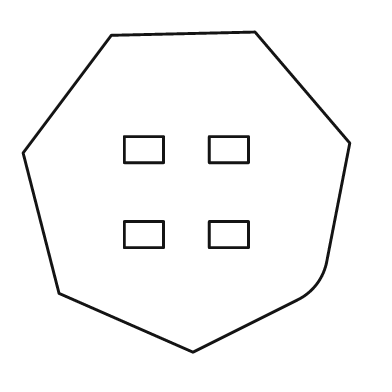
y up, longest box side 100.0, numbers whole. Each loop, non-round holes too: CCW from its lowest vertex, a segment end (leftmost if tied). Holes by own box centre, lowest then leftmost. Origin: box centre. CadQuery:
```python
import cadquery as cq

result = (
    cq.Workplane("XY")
    .moveTo(2.0, -49.0)
    .lineTo(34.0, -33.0)
    .threePointArc((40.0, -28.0), (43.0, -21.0))
    .lineTo(50.0, 15.0)
    .lineTo(21.0, 49.0)
    .lineTo(-23.0, 48.0)
    .lineTo(-50.0, 12.0)
    .lineTo(-39.0, -31.0)
    .close()
    .moveTo(-19.0, -17.0)
    .lineTo(-7.0, -17.0)
    .lineTo(-7.0, -9.0)
    .lineTo(-19.0, -9.0)
    .close()
    .moveTo(7.0, -17.0)
    .lineTo(19.0, -17.0)
    .lineTo(19.0, -9.0)
    .lineTo(7.0, -9.0)
    .close()
    .moveTo(-19.0, 9.0)
    .lineTo(-7.0, 9.0)
    .lineTo(-7.0, 17.0)
    .lineTo(-19.0, 17.0)
    .close()
    .moveTo(7.0, 9.0)
    .lineTo(19.0, 9.0)
    .lineTo(19.0, 17.0)
    .lineTo(7.0, 17.0)
    .close()
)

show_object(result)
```